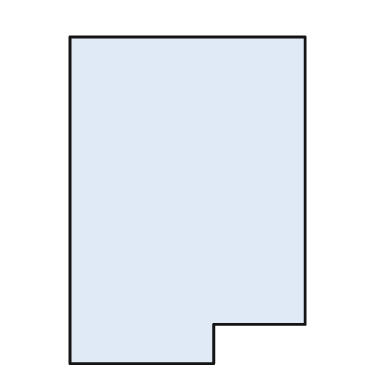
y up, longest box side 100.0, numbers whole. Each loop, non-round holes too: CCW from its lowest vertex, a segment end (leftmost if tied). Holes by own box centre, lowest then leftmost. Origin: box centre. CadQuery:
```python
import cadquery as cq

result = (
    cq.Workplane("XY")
    .moveTo(-36.0, -50.0)
    .lineTo(8.0, -50.0)
    .lineTo(8.0, -38.0)
    .lineTo(36.0, -38.0)
    .lineTo(36.0, 50.0)
    .lineTo(-36.0, 50.0)
    .close()
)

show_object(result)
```